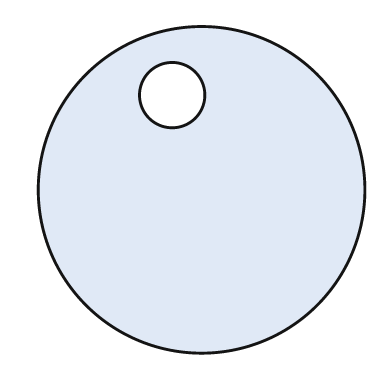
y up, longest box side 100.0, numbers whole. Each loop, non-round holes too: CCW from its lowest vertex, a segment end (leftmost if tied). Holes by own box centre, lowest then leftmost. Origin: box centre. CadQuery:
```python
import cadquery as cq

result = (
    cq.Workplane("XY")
    .moveTo(0.0, 0.0)
    .circle(50.0)
    .moveTo(-9.0, 29.0)
    .circle(10.0)
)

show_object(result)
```